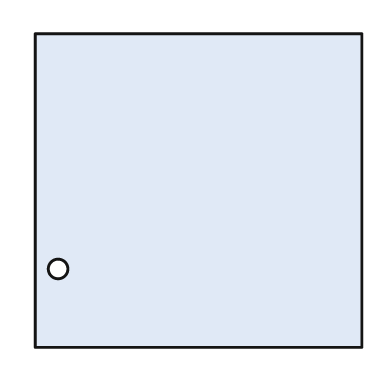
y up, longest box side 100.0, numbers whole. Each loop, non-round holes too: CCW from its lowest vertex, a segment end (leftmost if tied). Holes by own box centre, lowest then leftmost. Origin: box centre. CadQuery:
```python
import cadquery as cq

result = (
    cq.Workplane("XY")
    .moveTo(-50.0, -48.0)
    .lineTo(50.0, -48.0)
    .lineTo(50.0, 48.0)
    .lineTo(-50.0, 48.0)
    .close()
    .moveTo(-43.0, -24.0)
    .circle(3.0)
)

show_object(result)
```